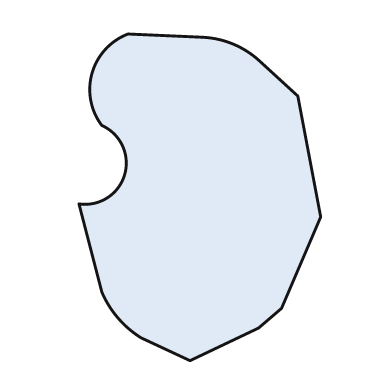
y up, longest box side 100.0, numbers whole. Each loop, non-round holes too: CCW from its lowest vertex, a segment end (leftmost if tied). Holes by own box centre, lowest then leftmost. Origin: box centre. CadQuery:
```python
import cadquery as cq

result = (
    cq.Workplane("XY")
    .moveTo(-3.0, -50.0)
    .lineTo(18.0, -40.0)
    .lineTo(25.0, -34.0)
    .lineTo(37.0, -6.0)
    .lineTo(30.0, 31.0)
    .lineTo(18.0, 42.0)
    .threePointArc((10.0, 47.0), (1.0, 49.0))
    .lineTo(-22.0, 50.0)
    .threePointArc((-33.0, 38.0), (-30.0, 22.0))
    .threePointArc((-23.0, 7.0), (-37.0, -2.0))
    .lineTo(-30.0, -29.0)
    .threePointArc((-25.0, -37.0), (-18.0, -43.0))
    .close()
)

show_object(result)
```